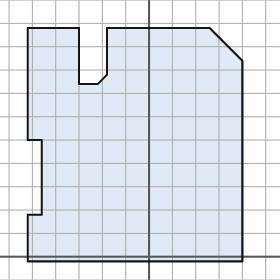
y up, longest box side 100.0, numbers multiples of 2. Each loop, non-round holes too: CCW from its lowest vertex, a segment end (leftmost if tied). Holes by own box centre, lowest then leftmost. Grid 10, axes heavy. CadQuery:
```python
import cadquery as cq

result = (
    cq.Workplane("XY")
    .moveTo(-52.0, -2.0)
    .lineTo(40.0, -2.0)
    .lineTo(40.0, 84.0)
    .lineTo(26.0, 98.0)
    .lineTo(-18.0, 98.0)
    .lineTo(-18.0, 78.0)
    .lineTo(-22.0, 74.0)
    .lineTo(-30.0, 74.0)
    .lineTo(-30.0, 98.0)
    .lineTo(-52.0, 98.0)
    .lineTo(-52.0, 50.0)
    .lineTo(-46.0, 50.0)
    .lineTo(-46.0, 18.0)
    .lineTo(-52.0, 18.0)
    .close()
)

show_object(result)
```